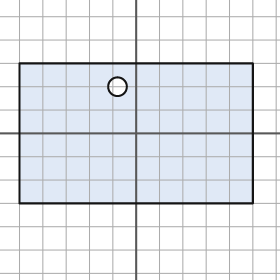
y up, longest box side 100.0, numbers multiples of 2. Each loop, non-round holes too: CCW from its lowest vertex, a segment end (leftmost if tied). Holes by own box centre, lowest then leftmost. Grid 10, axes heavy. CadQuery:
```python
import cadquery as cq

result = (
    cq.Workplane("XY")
    .moveTo(-50.0, -30.0)
    .lineTo(50.0, -30.0)
    .lineTo(50.0, 30.0)
    .lineTo(-50.0, 30.0)
    .close()
    .moveTo(-8.0, 20.0)
    .circle(4.0)
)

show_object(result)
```